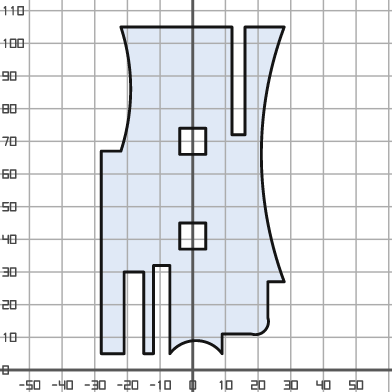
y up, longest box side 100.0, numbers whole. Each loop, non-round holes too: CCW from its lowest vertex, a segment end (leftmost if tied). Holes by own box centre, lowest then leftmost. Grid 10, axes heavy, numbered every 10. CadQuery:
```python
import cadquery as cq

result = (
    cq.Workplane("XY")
    .moveTo(-28.0, 5.0)
    .lineTo(-21.0, 5.0)
    .lineTo(-21.0, 30.0)
    .lineTo(-15.0, 30.0)
    .lineTo(-15.0, 5.0)
    .lineTo(-12.0, 5.0)
    .lineTo(-12.0, 32.0)
    .lineTo(-7.0, 32.0)
    .lineTo(-7.0, 5.0)
    .threePointArc((1.0, 9.0), (9.0, 5.0))
    .lineTo(9.0, 11.0)
    .lineTo(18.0, 11.0)
    .threePointArc((22.0, 12.0), (23.0, 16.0))
    .lineTo(23.0, 27.0)
    .lineTo(28.0, 27.0)
    .threePointArc((21.0, 66.0), (28.0, 105.0))
    .lineTo(16.0, 105.0)
    .lineTo(16.0, 72.0)
    .lineTo(12.0, 72.0)
    .lineTo(12.0, 105.0)
    .lineTo(-22.0, 105.0)
    .threePointArc((-19.0, 86.0), (-22.0, 67.0))
    .lineTo(-28.0, 67.0)
    .close()
    .moveTo(-4.0, 37.0)
    .lineTo(4.0, 37.0)
    .lineTo(4.0, 45.0)
    .lineTo(-4.0, 45.0)
    .close()
    .moveTo(-4.0, 66.0)
    .lineTo(4.0, 66.0)
    .lineTo(4.0, 74.0)
    .lineTo(-4.0, 74.0)
    .close()
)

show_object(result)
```